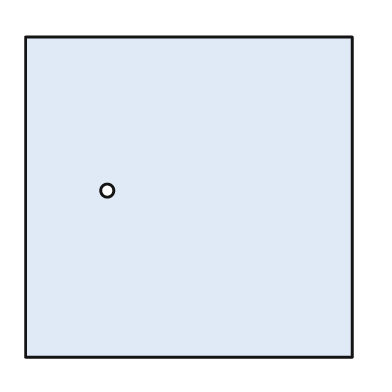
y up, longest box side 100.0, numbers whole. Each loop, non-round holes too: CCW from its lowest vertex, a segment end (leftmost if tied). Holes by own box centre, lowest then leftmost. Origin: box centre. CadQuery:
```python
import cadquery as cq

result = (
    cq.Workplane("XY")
    .moveTo(-50.0, -49.0)
    .lineTo(50.0, -49.0)
    .lineTo(50.0, 49.0)
    .lineTo(-50.0, 49.0)
    .close()
    .moveTo(-25.0, 2.0)
    .circle(2.0)
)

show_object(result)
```